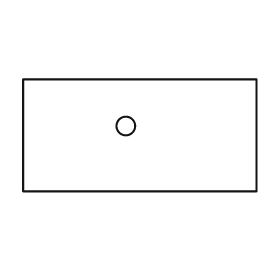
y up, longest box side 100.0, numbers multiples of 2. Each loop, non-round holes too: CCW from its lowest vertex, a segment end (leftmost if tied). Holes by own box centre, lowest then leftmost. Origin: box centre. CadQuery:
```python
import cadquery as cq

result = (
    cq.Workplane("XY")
    .moveTo(-50.0, -24.0)
    .lineTo(50.0, -24.0)
    .lineTo(50.0, 24.0)
    .lineTo(-50.0, 24.0)
    .close()
    .moveTo(-6.0, 4.0)
    .circle(4.0)
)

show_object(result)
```